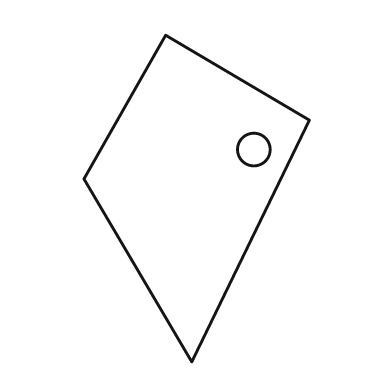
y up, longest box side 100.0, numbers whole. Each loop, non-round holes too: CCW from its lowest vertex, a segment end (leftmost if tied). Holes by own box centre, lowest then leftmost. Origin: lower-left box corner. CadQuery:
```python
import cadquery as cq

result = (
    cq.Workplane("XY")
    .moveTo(33.0, 0.0)
    .lineTo(69.0, 74.0)
    .lineTo(25.0, 100.0)
    .lineTo(0.0, 56.0)
    .close()
    .moveTo(52.0, 65.0)
    .circle(5.0)
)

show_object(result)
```